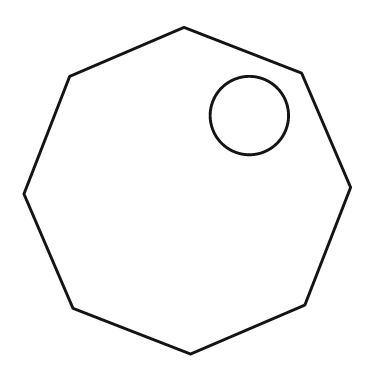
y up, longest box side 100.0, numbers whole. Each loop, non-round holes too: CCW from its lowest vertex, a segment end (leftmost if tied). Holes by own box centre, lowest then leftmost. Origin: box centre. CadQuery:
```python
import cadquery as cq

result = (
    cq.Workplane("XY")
    .moveTo(1.0, -50.0)
    .lineTo(36.0, -35.0)
    .lineTo(50.0, 1.0)
    .lineTo(35.0, 36.0)
    .lineTo(-1.0, 50.0)
    .lineTo(-36.0, 35.0)
    .lineTo(-50.0, -1.0)
    .lineTo(-35.0, -36.0)
    .close()
    .moveTo(19.0, 23.0)
    .circle(12.0)
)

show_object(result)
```